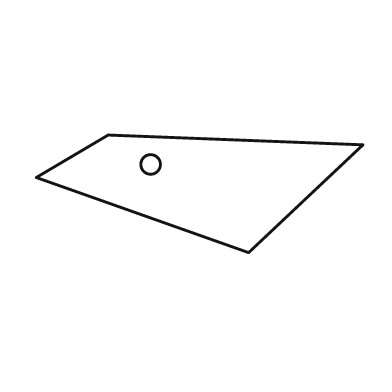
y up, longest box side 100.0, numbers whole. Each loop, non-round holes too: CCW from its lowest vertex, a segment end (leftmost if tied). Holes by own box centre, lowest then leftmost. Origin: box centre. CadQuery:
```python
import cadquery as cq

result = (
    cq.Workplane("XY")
    .moveTo(15.0, -18.0)
    .lineTo(50.0, 15.0)
    .lineTo(-28.0, 18.0)
    .lineTo(-50.0, 5.0)
    .close()
    .moveTo(-15.0, 9.0)
    .circle(3.0)
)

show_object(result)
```